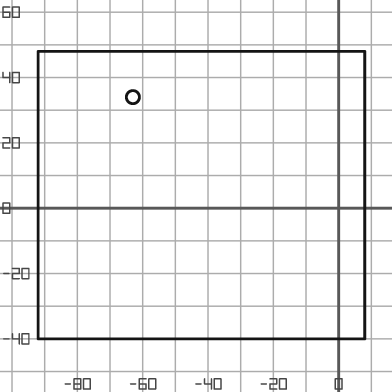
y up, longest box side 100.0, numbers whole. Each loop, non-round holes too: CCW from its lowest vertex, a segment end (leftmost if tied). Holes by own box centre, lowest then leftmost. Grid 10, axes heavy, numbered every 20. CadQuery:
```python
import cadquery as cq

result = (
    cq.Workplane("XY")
    .moveTo(-92.0, -40.0)
    .lineTo(8.0, -40.0)
    .lineTo(8.0, 48.0)
    .lineTo(-92.0, 48.0)
    .close()
    .moveTo(-63.0, 34.0)
    .circle(2.0)
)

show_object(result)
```